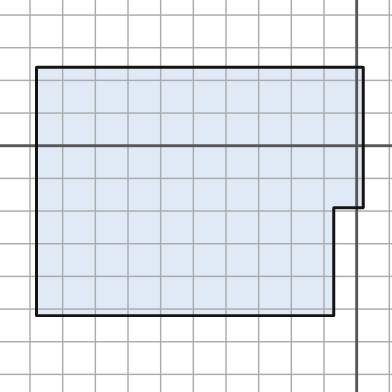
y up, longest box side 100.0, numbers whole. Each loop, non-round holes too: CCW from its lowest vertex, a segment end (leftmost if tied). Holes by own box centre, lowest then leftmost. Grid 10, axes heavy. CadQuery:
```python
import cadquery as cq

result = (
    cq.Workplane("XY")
    .moveTo(-98.0, -52.0)
    .lineTo(-7.0, -52.0)
    .lineTo(-7.0, -19.0)
    .lineTo(2.0, -19.0)
    .lineTo(2.0, 24.0)
    .lineTo(-98.0, 24.0)
    .close()
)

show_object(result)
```